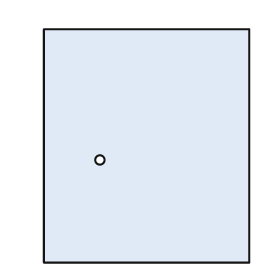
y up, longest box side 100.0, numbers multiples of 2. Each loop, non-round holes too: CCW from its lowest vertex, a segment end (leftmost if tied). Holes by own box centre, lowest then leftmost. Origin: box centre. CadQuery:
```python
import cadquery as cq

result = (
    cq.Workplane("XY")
    .moveTo(-44.0, -50.0)
    .lineTo(44.0, -50.0)
    .lineTo(44.0, 50.0)
    .lineTo(-44.0, 50.0)
    .close()
    .moveTo(-20.0, -6.0)
    .circle(2.0)
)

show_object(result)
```